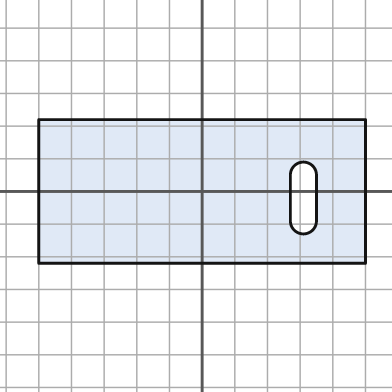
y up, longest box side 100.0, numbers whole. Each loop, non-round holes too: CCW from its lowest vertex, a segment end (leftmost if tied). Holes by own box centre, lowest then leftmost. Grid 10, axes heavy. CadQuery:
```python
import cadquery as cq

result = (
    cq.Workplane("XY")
    .moveTo(-50.0, -22.0)
    .lineTo(50.0, -22.0)
    .lineTo(50.0, 22.0)
    .lineTo(-50.0, 22.0)
    .close()
    .moveTo(27.0, -9.0)
    .threePointArc((31.0, -13.0), (35.0, -9.0))
    .lineTo(35.0, 5.0)
    .threePointArc((31.0, 9.0), (27.0, 5.0))
    .close()
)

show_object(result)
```